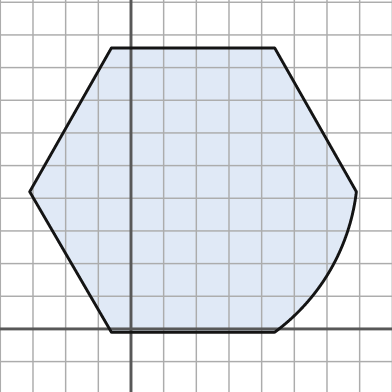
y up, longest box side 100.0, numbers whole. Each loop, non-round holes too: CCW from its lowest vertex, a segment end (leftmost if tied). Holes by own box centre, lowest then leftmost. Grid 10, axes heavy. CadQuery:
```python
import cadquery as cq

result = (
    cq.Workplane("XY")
    .moveTo(-6.0, -1.0)
    .lineTo(44.0, -1.0)
    .threePointArc((61.0, 18.0), (69.0, 42.0))
    .lineTo(44.0, 86.0)
    .lineTo(-6.0, 86.0)
    .lineTo(-31.0, 42.0)
    .close()
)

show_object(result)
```